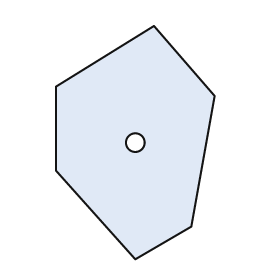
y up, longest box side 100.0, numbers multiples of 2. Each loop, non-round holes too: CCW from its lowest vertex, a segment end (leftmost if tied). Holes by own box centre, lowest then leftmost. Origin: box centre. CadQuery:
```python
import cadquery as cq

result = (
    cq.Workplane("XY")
    .moveTo(0.0, -50.0)
    .lineTo(24.0, -36.0)
    .lineTo(34.0, 20.0)
    .lineTo(8.0, 50.0)
    .lineTo(-34.0, 24.0)
    .lineTo(-34.0, -12.0)
    .close()
    .moveTo(0.0, 0.0)
    .circle(4.0)
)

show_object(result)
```